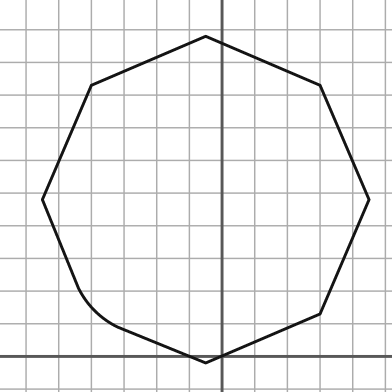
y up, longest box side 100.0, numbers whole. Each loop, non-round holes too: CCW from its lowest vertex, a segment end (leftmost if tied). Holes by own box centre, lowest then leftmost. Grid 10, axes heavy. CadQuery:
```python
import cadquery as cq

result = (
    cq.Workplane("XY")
    .moveTo(-5.0, -2.0)
    .lineTo(30.0, 13.0)
    .lineTo(45.0, 48.0)
    .lineTo(30.0, 83.0)
    .lineTo(-5.0, 98.0)
    .lineTo(-40.0, 83.0)
    .lineTo(-55.0, 48.0)
    .lineTo(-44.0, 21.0)
    .threePointArc((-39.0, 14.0), (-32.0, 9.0))
    .close()
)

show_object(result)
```